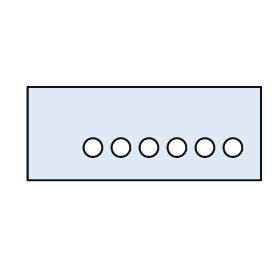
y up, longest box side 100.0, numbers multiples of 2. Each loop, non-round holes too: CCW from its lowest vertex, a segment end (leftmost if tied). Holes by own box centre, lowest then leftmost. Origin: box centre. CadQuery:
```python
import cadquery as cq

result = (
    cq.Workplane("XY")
    .moveTo(-50.0, -20.0)
    .lineTo(50.0, -20.0)
    .lineTo(50.0, 20.0)
    .lineTo(-50.0, 20.0)
    .close()
    .moveTo(-22.0, -6.0)
    .circle(4.0)
    .moveTo(-10.0, -6.0)
    .circle(4.0)
    .moveTo(2.0, -6.0)
    .circle(4.0)
    .moveTo(14.0, -6.0)
    .circle(4.0)
    .moveTo(26.0, -6.0)
    .circle(4.0)
    .moveTo(38.0, -6.0)
    .circle(4.0)
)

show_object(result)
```